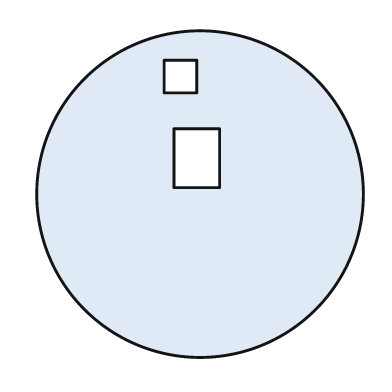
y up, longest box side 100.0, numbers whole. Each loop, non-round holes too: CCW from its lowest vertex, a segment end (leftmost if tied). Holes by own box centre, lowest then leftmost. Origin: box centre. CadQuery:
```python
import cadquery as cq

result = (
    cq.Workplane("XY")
    .moveTo(0.0, 0.0)
    .circle(50.0)
    .moveTo(-8.0, 2.0)
    .lineTo(6.0, 2.0)
    .lineTo(6.0, 20.0)
    .lineTo(-8.0, 20.0)
    .close()
    .moveTo(-11.0, 31.0)
    .lineTo(-1.0, 31.0)
    .lineTo(-1.0, 41.0)
    .lineTo(-11.0, 41.0)
    .close()
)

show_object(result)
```